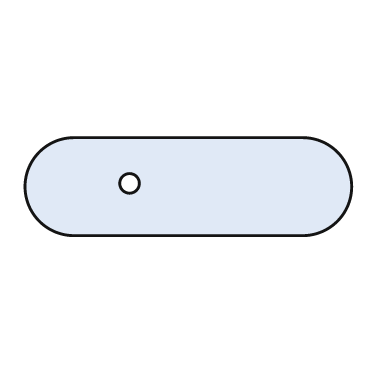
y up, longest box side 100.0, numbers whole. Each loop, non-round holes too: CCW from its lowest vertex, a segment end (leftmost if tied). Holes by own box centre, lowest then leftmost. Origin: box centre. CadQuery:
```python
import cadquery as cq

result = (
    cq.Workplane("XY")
    .moveTo(-35.0, -15.0)
    .lineTo(35.0, -15.0)
    .threePointArc((50.0, 0.0), (35.0, 15.0))
    .lineTo(-35.0, 15.0)
    .threePointArc((-50.0, 0.0), (-35.0, -15.0))
    .close()
    .moveTo(-18.0, 1.0)
    .circle(3.0)
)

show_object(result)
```